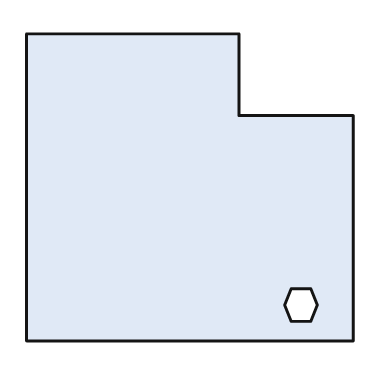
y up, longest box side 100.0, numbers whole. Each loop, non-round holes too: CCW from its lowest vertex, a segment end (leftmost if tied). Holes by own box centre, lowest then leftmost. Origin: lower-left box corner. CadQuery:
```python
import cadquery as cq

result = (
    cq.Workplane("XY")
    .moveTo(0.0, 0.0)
    .lineTo(100.0, 0.0)
    .lineTo(100.0, 69.0)
    .lineTo(65.0, 69.0)
    .lineTo(65.0, 94.0)
    .lineTo(0.0, 94.0)
    .close()
    .moveTo(81.0, 6.0)
    .lineTo(87.0, 6.0)
    .lineTo(89.0, 11.0)
    .lineTo(87.0, 16.0)
    .lineTo(81.0, 16.0)
    .lineTo(79.0, 11.0)
    .close()
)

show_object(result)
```